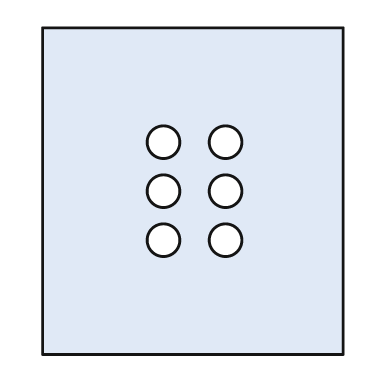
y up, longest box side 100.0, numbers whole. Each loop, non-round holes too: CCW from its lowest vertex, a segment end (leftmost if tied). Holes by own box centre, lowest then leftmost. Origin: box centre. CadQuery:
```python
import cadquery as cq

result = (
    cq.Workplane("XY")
    .moveTo(-46.0, -50.0)
    .lineTo(46.0, -50.0)
    .lineTo(46.0, 50.0)
    .lineTo(-46.0, 50.0)
    .close()
    .moveTo(-9.0, -15.0)
    .circle(5.0)
    .moveTo(10.0, -15.0)
    .circle(5.0)
    .moveTo(-9.0, 0.0)
    .circle(5.0)
    .moveTo(10.0, 0.0)
    .circle(5.0)
    .moveTo(-9.0, 15.0)
    .circle(5.0)
    .moveTo(10.0, 15.0)
    .circle(5.0)
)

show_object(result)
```